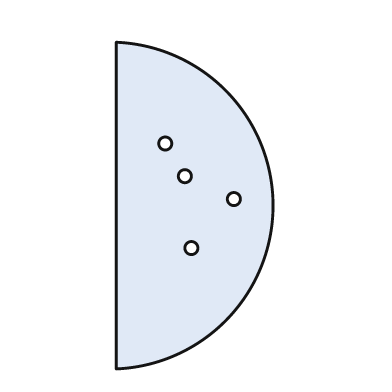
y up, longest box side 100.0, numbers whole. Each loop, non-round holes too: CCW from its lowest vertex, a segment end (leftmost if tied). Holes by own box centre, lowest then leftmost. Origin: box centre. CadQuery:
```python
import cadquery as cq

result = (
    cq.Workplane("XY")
    .moveTo(-24.0, -50.0)
    .threePointArc((24.0, 0.0), (-24.0, 50.0))
    .close()
    .moveTo(-1.0, -13.0)
    .circle(2.0)
    .moveTo(12.0, 2.0)
    .circle(2.0)
    .moveTo(-3.0, 9.0)
    .circle(2.0)
    .moveTo(-9.0, 19.0)
    .circle(2.0)
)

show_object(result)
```